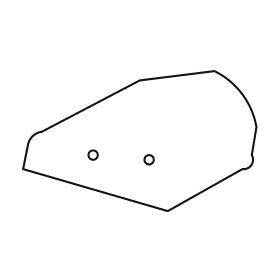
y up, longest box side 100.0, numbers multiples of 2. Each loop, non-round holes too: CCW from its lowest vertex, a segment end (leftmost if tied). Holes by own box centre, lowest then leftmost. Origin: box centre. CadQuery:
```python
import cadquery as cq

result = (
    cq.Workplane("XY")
    .moveTo(12.0, -30.0)
    .lineTo(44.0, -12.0)
    .threePointArc((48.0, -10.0), (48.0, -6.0))
    .lineTo(50.0, 6.0)
    .threePointArc((44.0, 20.0), (32.0, 30.0))
    .lineTo(0.0, 26.0)
    .lineTo(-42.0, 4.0)
    .threePointArc((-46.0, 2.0), (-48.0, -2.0))
    .lineTo(-50.0, -12.0)
    .close()
    .moveTo(4.0, -8.0)
    .circle(2.0)
    .moveTo(-20.0, -6.0)
    .circle(2.0)
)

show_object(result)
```